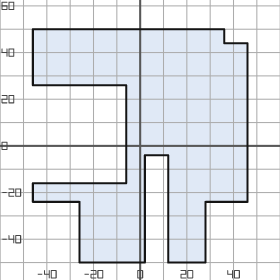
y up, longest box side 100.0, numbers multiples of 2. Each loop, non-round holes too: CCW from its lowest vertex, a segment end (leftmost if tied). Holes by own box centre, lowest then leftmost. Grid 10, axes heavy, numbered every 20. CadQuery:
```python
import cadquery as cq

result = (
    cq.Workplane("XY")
    .moveTo(-26.0, -50.0)
    .lineTo(2.0, -50.0)
    .lineTo(2.0, -4.0)
    .lineTo(12.0, -4.0)
    .lineTo(12.0, -50.0)
    .lineTo(28.0, -50.0)
    .lineTo(28.0, -24.0)
    .lineTo(46.0, -24.0)
    .lineTo(46.0, 44.0)
    .lineTo(36.0, 44.0)
    .lineTo(36.0, 50.0)
    .lineTo(-46.0, 50.0)
    .lineTo(-46.0, 26.0)
    .lineTo(-6.0, 26.0)
    .lineTo(-6.0, -16.0)
    .lineTo(-46.0, -16.0)
    .lineTo(-46.0, -24.0)
    .lineTo(-26.0, -24.0)
    .close()
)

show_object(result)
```